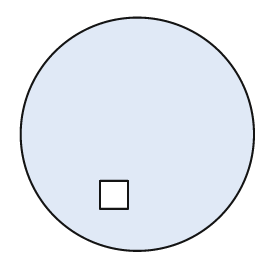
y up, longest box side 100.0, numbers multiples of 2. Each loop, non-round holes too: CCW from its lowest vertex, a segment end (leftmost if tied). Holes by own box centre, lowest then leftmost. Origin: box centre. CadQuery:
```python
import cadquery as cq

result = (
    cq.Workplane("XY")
    .moveTo(0.0, 0.0)
    .circle(50.0)
    .moveTo(-16.0, -32.0)
    .lineTo(-4.0, -32.0)
    .lineTo(-4.0, -20.0)
    .lineTo(-16.0, -20.0)
    .close()
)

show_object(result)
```